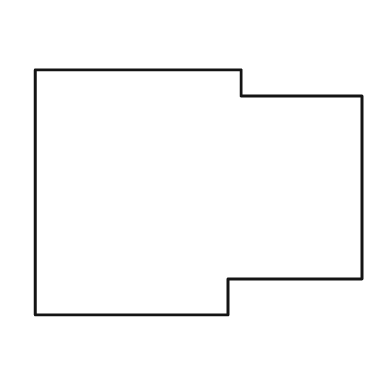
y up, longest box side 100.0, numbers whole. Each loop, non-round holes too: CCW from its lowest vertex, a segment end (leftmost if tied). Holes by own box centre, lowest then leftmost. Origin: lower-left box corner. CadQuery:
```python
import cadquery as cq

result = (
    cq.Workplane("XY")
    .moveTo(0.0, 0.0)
    .lineTo(59.0, 0.0)
    .lineTo(59.0, 11.0)
    .lineTo(100.0, 11.0)
    .lineTo(100.0, 67.0)
    .lineTo(63.0, 67.0)
    .lineTo(63.0, 75.0)
    .lineTo(0.0, 75.0)
    .close()
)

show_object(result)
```